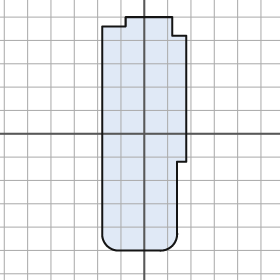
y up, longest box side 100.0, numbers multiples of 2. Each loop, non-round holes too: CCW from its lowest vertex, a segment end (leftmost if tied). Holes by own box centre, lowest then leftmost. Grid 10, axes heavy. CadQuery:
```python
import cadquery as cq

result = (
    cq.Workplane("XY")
    .moveTo(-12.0, -50.0)
    .lineTo(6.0, -50.0)
    .threePointArc((12.0, -48.0), (14.0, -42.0))
    .lineTo(14.0, -12.0)
    .lineTo(18.0, -12.0)
    .lineTo(18.0, 42.0)
    .lineTo(12.0, 42.0)
    .lineTo(12.0, 50.0)
    .lineTo(-8.0, 50.0)
    .lineTo(-8.0, 46.0)
    .lineTo(-18.0, 46.0)
    .lineTo(-18.0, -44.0)
    .threePointArc((-16.0, -48.0), (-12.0, -50.0))
    .close()
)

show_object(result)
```